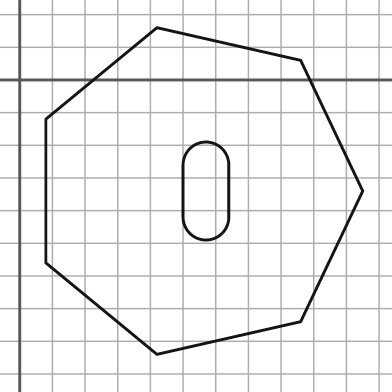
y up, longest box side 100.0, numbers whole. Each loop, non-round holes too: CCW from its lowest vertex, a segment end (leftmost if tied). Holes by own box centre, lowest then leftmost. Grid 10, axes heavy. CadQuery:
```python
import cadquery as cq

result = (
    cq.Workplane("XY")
    .moveTo(42.0, -84.0)
    .lineTo(86.0, -74.0)
    .lineTo(105.0, -34.0)
    .lineTo(86.0, 6.0)
    .lineTo(42.0, 16.0)
    .lineTo(8.0, -12.0)
    .lineTo(8.0, -56.0)
    .close()
    .moveTo(50.0, -42.0)
    .threePointArc((57.0, -49.0), (64.0, -42.0))
    .lineTo(64.0, -26.0)
    .threePointArc((57.0, -19.0), (50.0, -26.0))
    .close()
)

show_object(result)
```